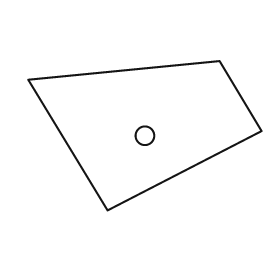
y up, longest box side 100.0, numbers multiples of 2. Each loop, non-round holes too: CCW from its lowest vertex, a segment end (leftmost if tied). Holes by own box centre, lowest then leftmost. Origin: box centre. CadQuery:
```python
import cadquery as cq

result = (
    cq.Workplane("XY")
    .moveTo(-16.0, -32.0)
    .lineTo(50.0, 2.0)
    .lineTo(32.0, 32.0)
    .lineTo(-50.0, 24.0)
    .close()
    .moveTo(0.0, 0.0)
    .circle(4.0)
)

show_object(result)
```